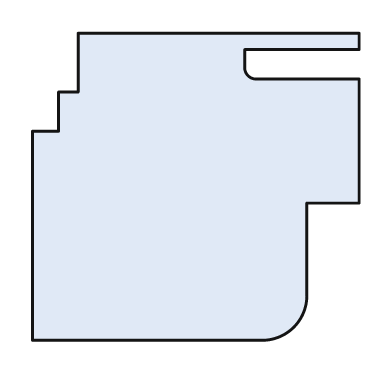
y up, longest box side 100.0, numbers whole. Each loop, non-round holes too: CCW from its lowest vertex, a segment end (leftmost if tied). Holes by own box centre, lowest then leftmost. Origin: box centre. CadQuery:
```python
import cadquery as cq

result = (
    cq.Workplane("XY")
    .moveTo(-50.0, -47.0)
    .lineTo(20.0, -47.0)
    .threePointArc((30.0, -43.0), (34.0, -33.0))
    .lineTo(34.0, -5.0)
    .lineTo(50.0, -5.0)
    .lineTo(50.0, 33.0)
    .lineTo(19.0, 33.0)
    .threePointArc((16.0, 34.0), (15.0, 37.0))
    .lineTo(15.0, 42.0)
    .lineTo(50.0, 42.0)
    .lineTo(50.0, 47.0)
    .lineTo(-36.0, 47.0)
    .lineTo(-36.0, 29.0)
    .lineTo(-42.0, 29.0)
    .lineTo(-42.0, 17.0)
    .lineTo(-50.0, 17.0)
    .close()
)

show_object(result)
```